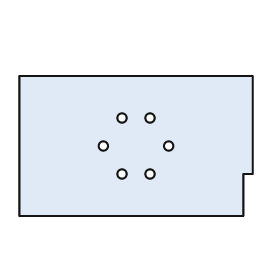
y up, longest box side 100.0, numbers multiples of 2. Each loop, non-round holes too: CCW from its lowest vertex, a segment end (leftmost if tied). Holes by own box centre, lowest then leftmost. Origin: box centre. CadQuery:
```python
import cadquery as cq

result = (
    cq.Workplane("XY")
    .moveTo(-50.0, -30.0)
    .lineTo(46.0, -30.0)
    .lineTo(46.0, -12.0)
    .lineTo(50.0, -12.0)
    .lineTo(50.0, 30.0)
    .lineTo(-50.0, 30.0)
    .close()
    .moveTo(-6.0, -12.0)
    .circle(2.0)
    .moveTo(6.0, -12.0)
    .circle(2.0)
    .moveTo(-14.0, 0.0)
    .circle(2.0)
    .moveTo(14.0, 0.0)
    .circle(2.0)
    .moveTo(-6.0, 12.0)
    .circle(2.0)
    .moveTo(6.0, 12.0)
    .circle(2.0)
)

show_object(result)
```